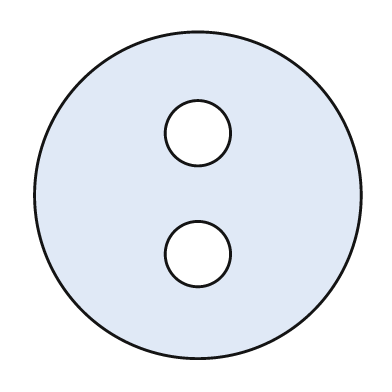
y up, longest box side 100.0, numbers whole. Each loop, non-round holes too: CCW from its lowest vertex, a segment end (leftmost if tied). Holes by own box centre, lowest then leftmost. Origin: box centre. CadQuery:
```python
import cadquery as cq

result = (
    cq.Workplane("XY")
    .moveTo(0.0, 0.0)
    .circle(50.0)
    .moveTo(0.0, -18.0)
    .circle(10.0)
    .moveTo(0.0, 19.0)
    .circle(10.0)
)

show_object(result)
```